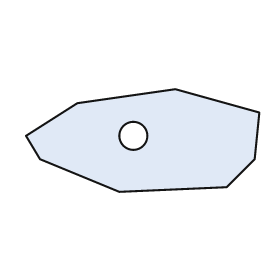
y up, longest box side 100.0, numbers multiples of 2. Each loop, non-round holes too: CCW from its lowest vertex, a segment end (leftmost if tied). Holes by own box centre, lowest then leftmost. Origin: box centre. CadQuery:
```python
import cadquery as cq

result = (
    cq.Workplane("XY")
    .moveTo(-10.0, -22.0)
    .lineTo(36.0, -20.0)
    .lineTo(48.0, -8.0)
    .lineTo(50.0, 12.0)
    .lineTo(14.0, 22.0)
    .lineTo(-28.0, 16.0)
    .lineTo(-50.0, 2.0)
    .lineTo(-44.0, -8.0)
    .close()
    .moveTo(-4.0, 2.0)
    .circle(6.0)
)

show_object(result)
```